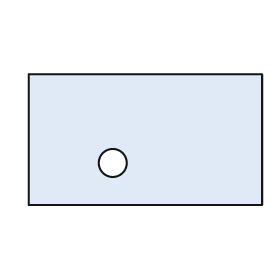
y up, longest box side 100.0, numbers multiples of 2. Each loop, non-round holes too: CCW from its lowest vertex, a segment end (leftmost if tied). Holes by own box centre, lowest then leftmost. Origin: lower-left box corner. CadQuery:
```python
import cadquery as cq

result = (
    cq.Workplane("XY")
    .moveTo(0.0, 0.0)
    .lineTo(100.0, 0.0)
    .lineTo(100.0, 56.0)
    .lineTo(0.0, 56.0)
    .close()
    .moveTo(36.0, 18.0)
    .circle(6.0)
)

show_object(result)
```